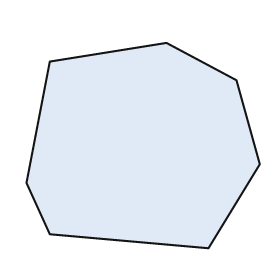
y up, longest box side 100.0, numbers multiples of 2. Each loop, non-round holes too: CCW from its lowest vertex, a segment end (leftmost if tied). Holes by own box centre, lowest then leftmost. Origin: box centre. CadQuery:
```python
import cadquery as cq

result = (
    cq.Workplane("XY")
    .moveTo(28.0, -44.0)
    .lineTo(50.0, -8.0)
    .lineTo(40.0, 28.0)
    .lineTo(10.0, 44.0)
    .lineTo(-40.0, 36.0)
    .lineTo(-50.0, -16.0)
    .lineTo(-40.0, -38.0)
    .close()
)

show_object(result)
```